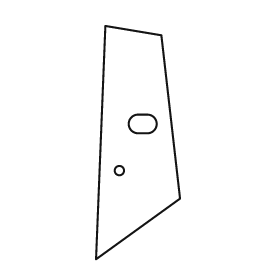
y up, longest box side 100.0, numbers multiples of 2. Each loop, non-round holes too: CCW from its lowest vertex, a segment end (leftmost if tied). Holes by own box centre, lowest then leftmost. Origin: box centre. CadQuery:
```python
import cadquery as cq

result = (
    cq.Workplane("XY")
    .moveTo(-18.0, -50.0)
    .lineTo(18.0, -24.0)
    .lineTo(10.0, 46.0)
    .lineTo(-14.0, 50.0)
    .close()
    .moveTo(-8.0, -12.0)
    .circle(2.0)
    .moveTo(0.0, 4.0)
    .lineTo(4.0, 4.0)
    .threePointArc((8.0, 8.0), (4.0, 12.0))
    .lineTo(0.0, 12.0)
    .threePointArc((-4.0, 8.0), (0.0, 4.0))
    .close()
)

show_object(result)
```